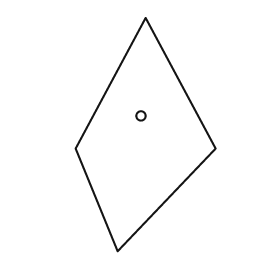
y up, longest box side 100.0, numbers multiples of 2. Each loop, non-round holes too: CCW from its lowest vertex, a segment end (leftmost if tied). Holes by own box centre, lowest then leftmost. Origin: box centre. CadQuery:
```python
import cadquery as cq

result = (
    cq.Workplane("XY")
    .moveTo(-12.0, -50.0)
    .lineTo(30.0, -6.0)
    .lineTo(0.0, 50.0)
    .lineTo(-30.0, -6.0)
    .close()
    .moveTo(-2.0, 8.0)
    .circle(2.0)
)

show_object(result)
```